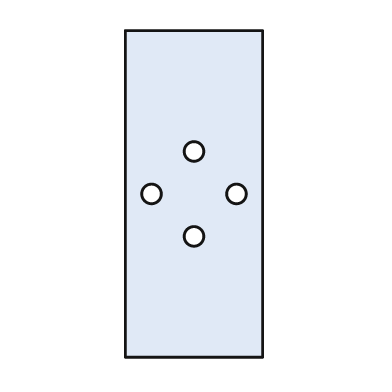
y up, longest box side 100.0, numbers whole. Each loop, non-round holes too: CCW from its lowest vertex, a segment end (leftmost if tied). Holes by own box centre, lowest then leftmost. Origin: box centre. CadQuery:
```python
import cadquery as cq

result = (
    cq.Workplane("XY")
    .moveTo(-21.0, -50.0)
    .lineTo(21.0, -50.0)
    .lineTo(21.0, 50.0)
    .lineTo(-21.0, 50.0)
    .close()
    .moveTo(0.0, -13.0)
    .circle(3.0)
    .moveTo(-13.0, 0.0)
    .circle(3.0)
    .moveTo(13.0, 0.0)
    .circle(3.0)
    .moveTo(0.0, 13.0)
    .circle(3.0)
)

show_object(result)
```